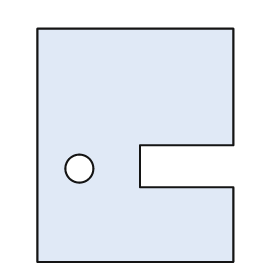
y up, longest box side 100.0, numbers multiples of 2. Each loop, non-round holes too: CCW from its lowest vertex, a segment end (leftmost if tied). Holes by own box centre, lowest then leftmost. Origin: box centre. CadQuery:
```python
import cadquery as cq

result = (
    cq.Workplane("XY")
    .moveTo(-42.0, -50.0)
    .lineTo(42.0, -50.0)
    .lineTo(42.0, -18.0)
    .lineTo(2.0, -18.0)
    .lineTo(2.0, 0.0)
    .lineTo(42.0, 0.0)
    .lineTo(42.0, 50.0)
    .lineTo(-42.0, 50.0)
    .close()
    .moveTo(-24.0, -10.0)
    .circle(6.0)
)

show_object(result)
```